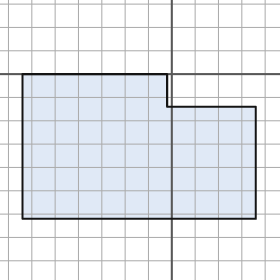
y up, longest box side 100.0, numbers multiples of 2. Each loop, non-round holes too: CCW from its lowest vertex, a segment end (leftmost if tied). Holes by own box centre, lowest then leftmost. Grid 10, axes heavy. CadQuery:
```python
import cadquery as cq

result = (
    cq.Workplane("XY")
    .moveTo(-64.0, -62.0)
    .lineTo(36.0, -62.0)
    .lineTo(36.0, -14.0)
    .lineTo(-2.0, -14.0)
    .lineTo(-2.0, 0.0)
    .lineTo(-64.0, 0.0)
    .close()
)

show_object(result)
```